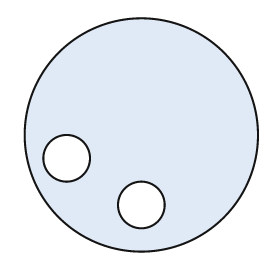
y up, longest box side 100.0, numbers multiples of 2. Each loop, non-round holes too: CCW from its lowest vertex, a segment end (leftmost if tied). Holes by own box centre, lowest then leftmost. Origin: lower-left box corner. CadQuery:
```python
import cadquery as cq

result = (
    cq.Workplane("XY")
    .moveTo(50.0, 50.0)
    .circle(50.0)
    .moveTo(50.0, 20.0)
    .circle(10.0)
    .moveTo(18.0, 40.0)
    .circle(10.0)
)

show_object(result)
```